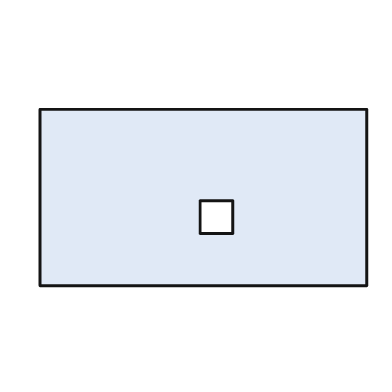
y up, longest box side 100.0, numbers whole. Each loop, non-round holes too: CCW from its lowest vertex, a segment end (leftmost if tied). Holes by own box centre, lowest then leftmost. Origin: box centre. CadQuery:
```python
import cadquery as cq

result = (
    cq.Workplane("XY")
    .moveTo(-50.0, -27.0)
    .lineTo(50.0, -27.0)
    .lineTo(50.0, 27.0)
    .lineTo(-50.0, 27.0)
    .close()
    .moveTo(-1.0, -11.0)
    .lineTo(9.0, -11.0)
    .lineTo(9.0, -1.0)
    .lineTo(-1.0, -1.0)
    .close()
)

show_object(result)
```